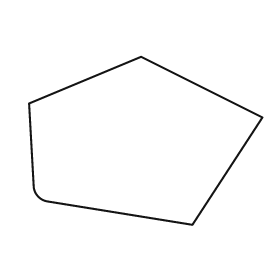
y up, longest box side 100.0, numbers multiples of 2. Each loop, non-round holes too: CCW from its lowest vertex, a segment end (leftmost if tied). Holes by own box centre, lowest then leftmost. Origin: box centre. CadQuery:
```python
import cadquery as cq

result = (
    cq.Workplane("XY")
    .moveTo(20.0, -36.0)
    .lineTo(50.0, 10.0)
    .lineTo(-2.0, 36.0)
    .lineTo(-50.0, 16.0)
    .lineTo(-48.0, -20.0)
    .threePointArc((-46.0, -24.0), (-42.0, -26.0))
    .close()
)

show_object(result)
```